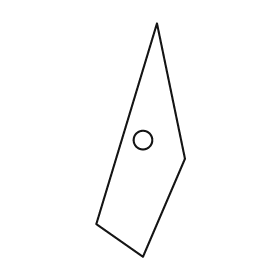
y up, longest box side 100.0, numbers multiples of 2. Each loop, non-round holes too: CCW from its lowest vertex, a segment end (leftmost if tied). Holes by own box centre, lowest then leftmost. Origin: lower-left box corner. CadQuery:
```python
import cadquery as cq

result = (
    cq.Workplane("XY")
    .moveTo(20.0, 0.0)
    .lineTo(38.0, 42.0)
    .lineTo(26.0, 100.0)
    .lineTo(0.0, 14.0)
    .close()
    .moveTo(20.0, 50.0)
    .circle(4.0)
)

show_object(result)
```